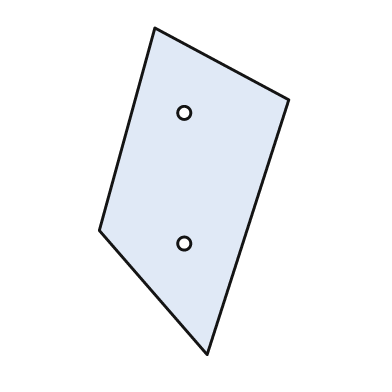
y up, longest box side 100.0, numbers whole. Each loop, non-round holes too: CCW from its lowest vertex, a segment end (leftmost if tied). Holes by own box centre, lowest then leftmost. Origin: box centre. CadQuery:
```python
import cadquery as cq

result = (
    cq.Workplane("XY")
    .moveTo(4.0, -50.0)
    .lineTo(29.0, 28.0)
    .lineTo(-12.0, 50.0)
    .lineTo(-29.0, -12.0)
    .close()
    .moveTo(-3.0, -16.0)
    .circle(2.0)
    .moveTo(-3.0, 24.0)
    .circle(2.0)
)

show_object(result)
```